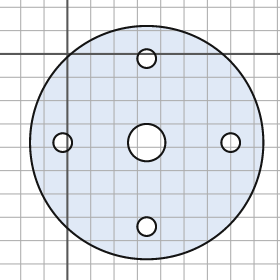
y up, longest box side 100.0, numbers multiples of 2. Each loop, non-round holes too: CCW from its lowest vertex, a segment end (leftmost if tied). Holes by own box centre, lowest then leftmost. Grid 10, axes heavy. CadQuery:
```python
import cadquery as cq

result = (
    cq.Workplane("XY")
    .moveTo(34.0, -38.0)
    .circle(50.0)
    .moveTo(34.0, -74.0)
    .circle(4.0)
    .moveTo(-2.0, -38.0)
    .circle(4.0)
    .moveTo(34.0, -38.0)
    .circle(8.0)
    .moveTo(70.0, -38.0)
    .circle(4.0)
    .moveTo(34.0, -2.0)
    .circle(4.0)
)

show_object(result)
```